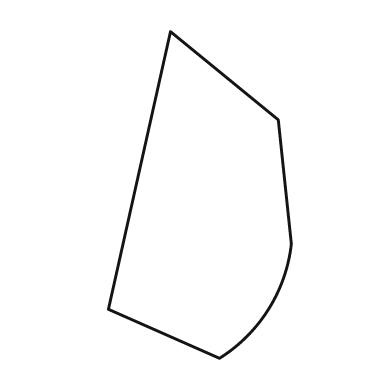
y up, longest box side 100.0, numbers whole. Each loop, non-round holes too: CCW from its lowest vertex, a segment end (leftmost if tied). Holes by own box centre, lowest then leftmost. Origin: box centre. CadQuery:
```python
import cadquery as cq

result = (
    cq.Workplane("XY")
    .moveTo(6.0, -50.0)
    .threePointArc((21.0, -35.0), (28.0, -15.0))
    .lineTo(24.0, 23.0)
    .lineTo(-9.0, 50.0)
    .lineTo(-28.0, -35.0)
    .close()
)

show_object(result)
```